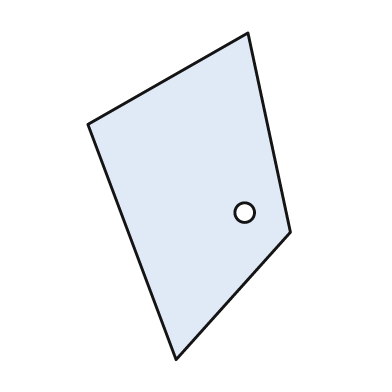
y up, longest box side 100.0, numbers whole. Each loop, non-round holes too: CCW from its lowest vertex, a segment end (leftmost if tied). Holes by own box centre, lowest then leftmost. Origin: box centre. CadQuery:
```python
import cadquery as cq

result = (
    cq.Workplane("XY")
    .moveTo(-4.0, -50.0)
    .lineTo(31.0, -11.0)
    .lineTo(18.0, 50.0)
    .lineTo(-31.0, 22.0)
    .close()
    .moveTo(17.0, -5.0)
    .circle(3.0)
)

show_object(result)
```